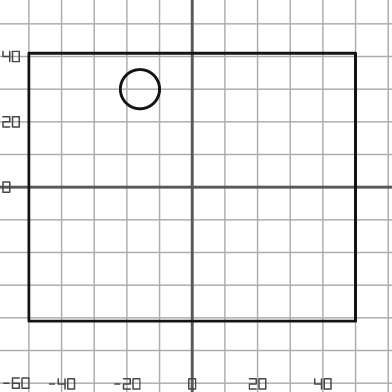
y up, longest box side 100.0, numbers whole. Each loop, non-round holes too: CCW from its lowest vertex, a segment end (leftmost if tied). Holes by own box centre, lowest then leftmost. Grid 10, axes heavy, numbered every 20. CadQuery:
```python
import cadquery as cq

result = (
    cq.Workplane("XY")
    .moveTo(-50.0, -41.0)
    .lineTo(50.0, -41.0)
    .lineTo(50.0, 41.0)
    .lineTo(-50.0, 41.0)
    .close()
    .moveTo(-16.0, 30.0)
    .circle(6.0)
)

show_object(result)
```